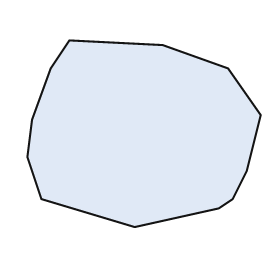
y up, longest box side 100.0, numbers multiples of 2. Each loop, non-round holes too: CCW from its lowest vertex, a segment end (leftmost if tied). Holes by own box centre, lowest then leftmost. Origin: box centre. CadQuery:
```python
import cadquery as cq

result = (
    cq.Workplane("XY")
    .moveTo(-4.0, -40.0)
    .lineTo(32.0, -32.0)
    .lineTo(38.0, -28.0)
    .lineTo(44.0, -16.0)
    .lineTo(50.0, 8.0)
    .lineTo(36.0, 28.0)
    .lineTo(8.0, 38.0)
    .lineTo(-32.0, 40.0)
    .lineTo(-40.0, 28.0)
    .lineTo(-48.0, 6.0)
    .lineTo(-50.0, -10.0)
    .lineTo(-44.0, -28.0)
    .close()
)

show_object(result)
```